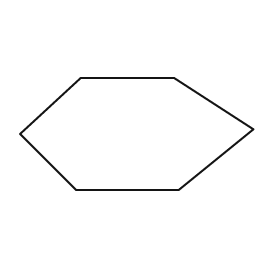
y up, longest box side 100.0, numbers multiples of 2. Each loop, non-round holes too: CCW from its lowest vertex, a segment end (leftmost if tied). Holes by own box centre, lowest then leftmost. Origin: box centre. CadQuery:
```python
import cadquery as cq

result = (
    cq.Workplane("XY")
    .moveTo(-26.0, -24.0)
    .lineTo(18.0, -24.0)
    .lineTo(50.0, 2.0)
    .lineTo(16.0, 24.0)
    .lineTo(-24.0, 24.0)
    .lineTo(-50.0, 0.0)
    .close()
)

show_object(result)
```